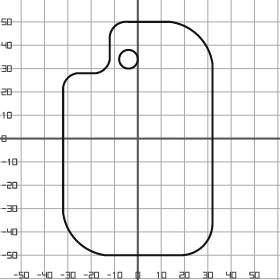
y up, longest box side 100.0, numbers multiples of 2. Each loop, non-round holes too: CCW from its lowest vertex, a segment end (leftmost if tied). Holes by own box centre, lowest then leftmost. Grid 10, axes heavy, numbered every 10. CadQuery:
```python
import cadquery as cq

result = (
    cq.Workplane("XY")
    .moveTo(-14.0, -50.0)
    .lineTo(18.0, -50.0)
    .threePointArc((28.0, -46.0), (32.0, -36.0))
    .lineTo(32.0, 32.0)
    .threePointArc((26.0, 44.0), (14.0, 50.0))
    .lineTo(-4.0, 50.0)
    .threePointArc((-10.0, 48.0), (-12.0, 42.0))
    .lineTo(-12.0, 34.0)
    .threePointArc((-14.0, 30.0), (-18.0, 28.0))
    .lineTo(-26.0, 28.0)
    .threePointArc((-30.0, 26.0), (-32.0, 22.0))
    .lineTo(-32.0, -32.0)
    .threePointArc((-26.0, -44.0), (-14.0, -50.0))
    .close()
    .moveTo(-4.0, 34.0)
    .circle(4.0)
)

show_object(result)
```